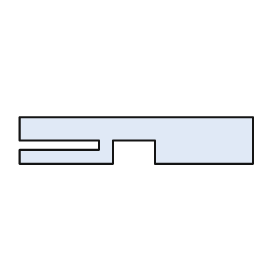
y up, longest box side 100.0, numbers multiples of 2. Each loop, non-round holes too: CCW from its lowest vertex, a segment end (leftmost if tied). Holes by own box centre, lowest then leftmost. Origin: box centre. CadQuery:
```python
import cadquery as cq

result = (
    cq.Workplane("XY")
    .moveTo(-50.0, -10.0)
    .lineTo(-10.0, -10.0)
    .lineTo(-10.0, 0.0)
    .lineTo(8.0, 0.0)
    .lineTo(8.0, -10.0)
    .lineTo(50.0, -10.0)
    .lineTo(50.0, 10.0)
    .lineTo(-50.0, 10.0)
    .lineTo(-50.0, 0.0)
    .lineTo(-16.0, 0.0)
    .lineTo(-16.0, -4.0)
    .lineTo(-50.0, -4.0)
    .close()
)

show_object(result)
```